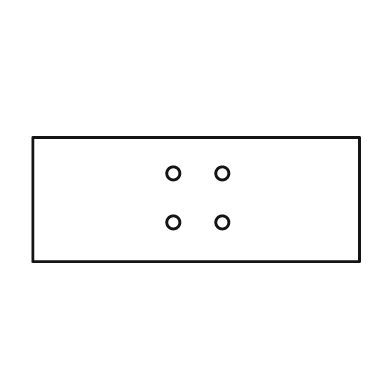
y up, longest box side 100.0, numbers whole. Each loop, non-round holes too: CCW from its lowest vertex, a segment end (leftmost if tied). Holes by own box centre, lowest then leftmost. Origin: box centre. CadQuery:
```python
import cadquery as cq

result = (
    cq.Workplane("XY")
    .moveTo(-50.0, -19.0)
    .lineTo(50.0, -19.0)
    .lineTo(50.0, 19.0)
    .lineTo(-50.0, 19.0)
    .close()
    .moveTo(-7.0, -7.0)
    .circle(2.0)
    .moveTo(8.0, -7.0)
    .circle(2.0)
    .moveTo(-7.0, 8.0)
    .circle(2.0)
    .moveTo(8.0, 8.0)
    .circle(2.0)
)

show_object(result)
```